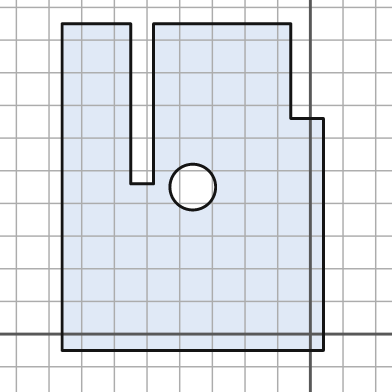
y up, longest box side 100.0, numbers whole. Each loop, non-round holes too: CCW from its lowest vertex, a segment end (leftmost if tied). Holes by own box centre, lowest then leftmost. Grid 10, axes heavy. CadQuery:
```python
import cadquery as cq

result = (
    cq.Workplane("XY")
    .moveTo(-76.0, -5.0)
    .lineTo(4.0, -5.0)
    .lineTo(4.0, 66.0)
    .lineTo(-6.0, 66.0)
    .lineTo(-6.0, 95.0)
    .lineTo(-48.0, 95.0)
    .lineTo(-48.0, 46.0)
    .lineTo(-55.0, 46.0)
    .lineTo(-55.0, 95.0)
    .lineTo(-76.0, 95.0)
    .close()
    .moveTo(-36.0, 45.0)
    .circle(7.0)
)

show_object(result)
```